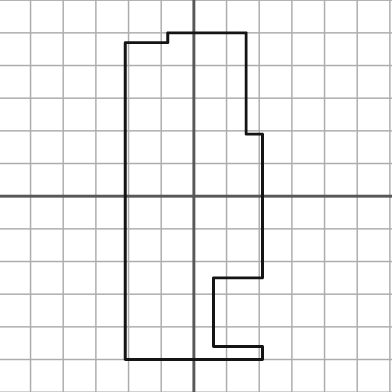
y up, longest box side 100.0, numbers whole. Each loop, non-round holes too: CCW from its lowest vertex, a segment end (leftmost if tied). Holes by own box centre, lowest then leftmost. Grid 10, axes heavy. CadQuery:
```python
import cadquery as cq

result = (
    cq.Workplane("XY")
    .moveTo(-21.0, -50.0)
    .lineTo(21.0, -50.0)
    .lineTo(21.0, -46.0)
    .lineTo(6.0, -46.0)
    .lineTo(6.0, -25.0)
    .lineTo(21.0, -25.0)
    .lineTo(21.0, 19.0)
    .lineTo(16.0, 19.0)
    .lineTo(16.0, 50.0)
    .lineTo(-8.0, 50.0)
    .lineTo(-8.0, 47.0)
    .lineTo(-21.0, 47.0)
    .close()
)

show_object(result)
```